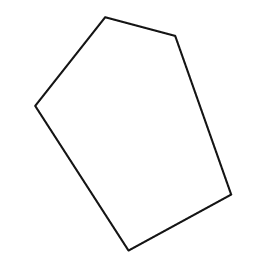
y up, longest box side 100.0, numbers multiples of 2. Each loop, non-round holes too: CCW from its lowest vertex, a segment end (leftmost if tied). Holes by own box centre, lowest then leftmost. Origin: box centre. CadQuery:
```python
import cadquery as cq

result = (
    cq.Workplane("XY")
    .moveTo(-2.0, -50.0)
    .lineTo(42.0, -26.0)
    .lineTo(18.0, 42.0)
    .lineTo(-12.0, 50.0)
    .lineTo(-42.0, 12.0)
    .close()
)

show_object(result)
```